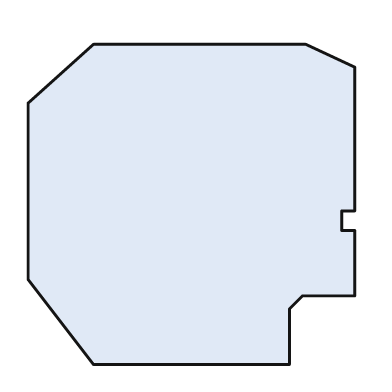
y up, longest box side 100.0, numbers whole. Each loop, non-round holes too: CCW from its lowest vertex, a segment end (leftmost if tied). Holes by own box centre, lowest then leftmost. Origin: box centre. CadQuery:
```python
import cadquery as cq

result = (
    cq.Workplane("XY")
    .moveTo(-30.0, -49.0)
    .lineTo(30.0, -49.0)
    .lineTo(30.0, -32.0)
    .lineTo(34.0, -28.0)
    .lineTo(50.0, -28.0)
    .lineTo(50.0, -8.0)
    .lineTo(46.0, -8.0)
    .lineTo(46.0, -2.0)
    .lineTo(50.0, -2.0)
    .lineTo(50.0, 42.0)
    .lineTo(35.0, 49.0)
    .lineTo(-30.0, 49.0)
    .lineTo(-50.0, 31.0)
    .lineTo(-50.0, -23.0)
    .close()
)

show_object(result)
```